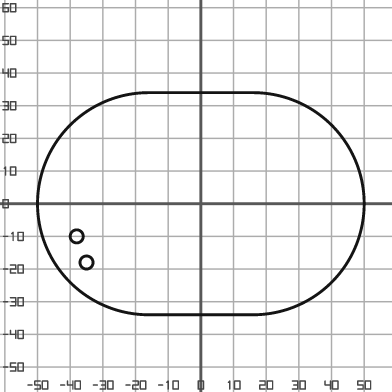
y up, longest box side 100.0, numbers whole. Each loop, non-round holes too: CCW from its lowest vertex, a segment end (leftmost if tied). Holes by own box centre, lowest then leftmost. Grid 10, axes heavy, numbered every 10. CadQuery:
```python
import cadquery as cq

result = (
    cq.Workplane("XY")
    .moveTo(-16.0, -34.0)
    .lineTo(16.0, -34.0)
    .threePointArc((50.0, 0.0), (16.0, 34.0))
    .lineTo(-16.0, 34.0)
    .threePointArc((-50.0, 0.0), (-16.0, -34.0))
    .close()
    .moveTo(-35.0, -18.0)
    .circle(2.0)
    .moveTo(-38.0, -10.0)
    .circle(2.0)
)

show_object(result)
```